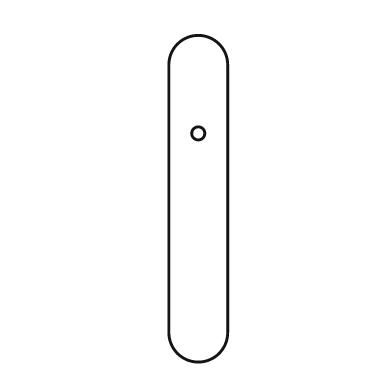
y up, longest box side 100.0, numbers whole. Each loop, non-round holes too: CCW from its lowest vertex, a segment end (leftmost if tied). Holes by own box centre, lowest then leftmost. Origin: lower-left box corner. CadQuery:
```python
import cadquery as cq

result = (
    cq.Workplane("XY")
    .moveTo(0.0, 9.0)
    .threePointArc((9.0, 0.0), (18.0, 9.0))
    .lineTo(18.0, 91.0)
    .threePointArc((9.0, 100.0), (0.0, 91.0))
    .close()
    .moveTo(9.0, 70.0)
    .circle(2.0)
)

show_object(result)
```